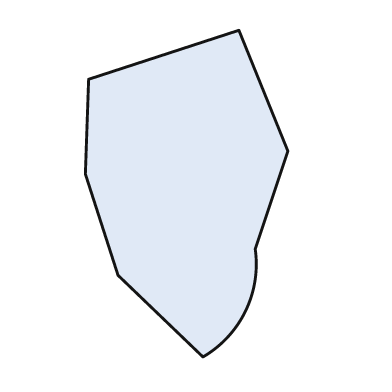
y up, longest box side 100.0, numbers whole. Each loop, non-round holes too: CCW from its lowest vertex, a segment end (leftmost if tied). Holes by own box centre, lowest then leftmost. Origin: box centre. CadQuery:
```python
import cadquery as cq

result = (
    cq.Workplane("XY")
    .moveTo(5.0, -50.0)
    .threePointArc((18.0, -36.0), (21.0, -17.0))
    .lineTo(31.0, 13.0)
    .lineTo(16.0, 50.0)
    .lineTo(-30.0, 35.0)
    .lineTo(-31.0, 6.0)
    .lineTo(-21.0, -25.0)
    .close()
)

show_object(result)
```